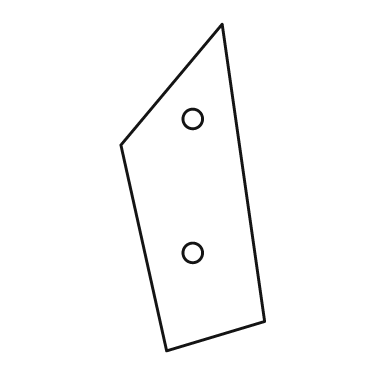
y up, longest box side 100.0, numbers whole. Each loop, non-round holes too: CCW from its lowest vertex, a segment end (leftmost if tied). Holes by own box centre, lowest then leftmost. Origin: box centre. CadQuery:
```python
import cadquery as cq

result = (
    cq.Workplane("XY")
    .moveTo(-8.0, -50.0)
    .lineTo(22.0, -41.0)
    .lineTo(9.0, 50.0)
    .lineTo(-22.0, 13.0)
    .close()
    .moveTo(0.0, -20.0)
    .circle(3.0)
    .moveTo(0.0, 21.0)
    .circle(3.0)
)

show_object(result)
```